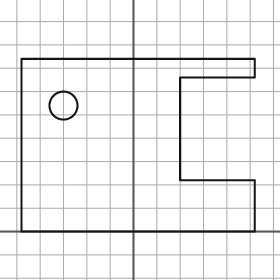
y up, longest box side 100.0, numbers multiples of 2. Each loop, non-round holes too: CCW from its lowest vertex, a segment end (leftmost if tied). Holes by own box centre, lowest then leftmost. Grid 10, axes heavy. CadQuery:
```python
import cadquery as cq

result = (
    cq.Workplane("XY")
    .moveTo(-48.0, 0.0)
    .lineTo(52.0, 0.0)
    .lineTo(52.0, 22.0)
    .lineTo(20.0, 22.0)
    .lineTo(20.0, 66.0)
    .lineTo(52.0, 66.0)
    .lineTo(52.0, 74.0)
    .lineTo(-48.0, 74.0)
    .close()
    .moveTo(-30.0, 54.0)
    .circle(6.0)
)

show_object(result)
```